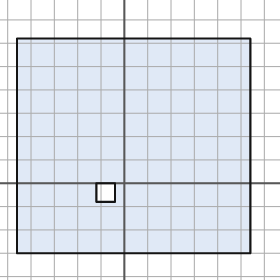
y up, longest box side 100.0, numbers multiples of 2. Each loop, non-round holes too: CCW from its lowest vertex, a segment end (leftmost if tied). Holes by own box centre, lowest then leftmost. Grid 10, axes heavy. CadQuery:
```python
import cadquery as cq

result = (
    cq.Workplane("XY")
    .moveTo(-46.0, -30.0)
    .lineTo(54.0, -30.0)
    .lineTo(54.0, 62.0)
    .lineTo(-46.0, 62.0)
    .close()
    .moveTo(-12.0, -8.0)
    .lineTo(-4.0, -8.0)
    .lineTo(-4.0, 0.0)
    .lineTo(-12.0, 0.0)
    .close()
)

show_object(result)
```